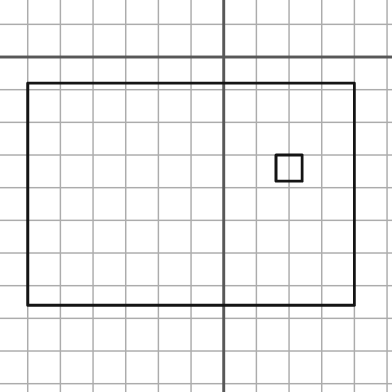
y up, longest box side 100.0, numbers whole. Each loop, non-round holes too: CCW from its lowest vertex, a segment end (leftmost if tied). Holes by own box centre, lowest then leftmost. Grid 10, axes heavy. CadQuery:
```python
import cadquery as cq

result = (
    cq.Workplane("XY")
    .moveTo(-60.0, -76.0)
    .lineTo(40.0, -76.0)
    .lineTo(40.0, -8.0)
    .lineTo(-60.0, -8.0)
    .close()
    .moveTo(16.0, -38.0)
    .lineTo(24.0, -38.0)
    .lineTo(24.0, -30.0)
    .lineTo(16.0, -30.0)
    .close()
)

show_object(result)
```